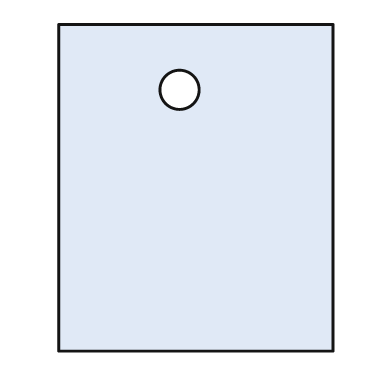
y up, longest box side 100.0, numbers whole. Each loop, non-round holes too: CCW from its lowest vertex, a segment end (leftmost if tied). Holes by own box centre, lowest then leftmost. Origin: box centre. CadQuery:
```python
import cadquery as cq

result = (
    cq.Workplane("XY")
    .moveTo(-42.0, -50.0)
    .lineTo(42.0, -50.0)
    .lineTo(42.0, 50.0)
    .lineTo(-42.0, 50.0)
    .close()
    .moveTo(-5.0, 30.0)
    .circle(6.0)
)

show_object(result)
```